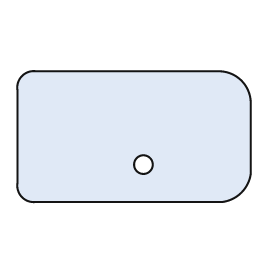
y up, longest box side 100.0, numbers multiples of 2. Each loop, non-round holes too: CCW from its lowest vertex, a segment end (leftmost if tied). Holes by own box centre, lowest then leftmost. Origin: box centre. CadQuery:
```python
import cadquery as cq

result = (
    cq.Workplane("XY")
    .moveTo(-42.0, -28.0)
    .lineTo(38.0, -28.0)
    .threePointArc((46.0, -24.0), (50.0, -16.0))
    .lineTo(50.0, 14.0)
    .threePointArc((46.0, 24.0), (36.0, 28.0))
    .lineTo(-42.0, 28.0)
    .threePointArc((-48.0, 26.0), (-50.0, 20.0))
    .lineTo(-50.0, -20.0)
    .threePointArc((-48.0, -26.0), (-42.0, -28.0))
    .close()
    .moveTo(4.0, -12.0)
    .circle(4.0)
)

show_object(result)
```